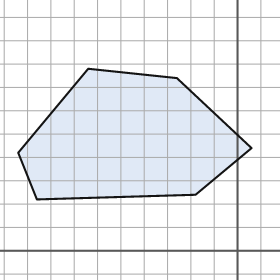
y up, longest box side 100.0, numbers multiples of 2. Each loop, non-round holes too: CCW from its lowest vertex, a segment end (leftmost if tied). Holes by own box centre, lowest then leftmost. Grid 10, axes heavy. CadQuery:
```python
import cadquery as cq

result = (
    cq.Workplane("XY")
    .moveTo(-86.0, 22.0)
    .lineTo(-18.0, 24.0)
    .lineTo(6.0, 44.0)
    .lineTo(-26.0, 74.0)
    .lineTo(-64.0, 78.0)
    .lineTo(-94.0, 42.0)
    .close()
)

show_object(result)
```